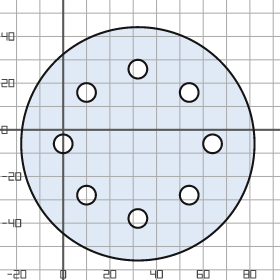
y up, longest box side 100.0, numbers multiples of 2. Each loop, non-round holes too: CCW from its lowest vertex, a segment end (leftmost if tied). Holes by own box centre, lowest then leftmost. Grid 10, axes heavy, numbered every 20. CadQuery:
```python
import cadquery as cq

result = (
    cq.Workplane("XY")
    .moveTo(32.0, -6.0)
    .circle(50.0)
    .moveTo(32.0, -38.0)
    .circle(4.0)
    .moveTo(10.0, -28.0)
    .circle(4.0)
    .moveTo(54.0, -28.0)
    .circle(4.0)
    .moveTo(0.0, -6.0)
    .circle(4.0)
    .moveTo(64.0, -6.0)
    .circle(4.0)
    .moveTo(10.0, 16.0)
    .circle(4.0)
    .moveTo(54.0, 16.0)
    .circle(4.0)
    .moveTo(32.0, 26.0)
    .circle(4.0)
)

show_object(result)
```